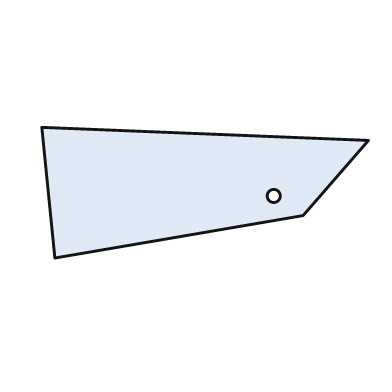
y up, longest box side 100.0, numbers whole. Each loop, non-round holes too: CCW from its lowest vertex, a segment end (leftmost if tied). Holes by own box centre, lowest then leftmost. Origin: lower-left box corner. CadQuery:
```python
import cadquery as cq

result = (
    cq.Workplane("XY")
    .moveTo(4.0, 0.0)
    .lineTo(80.0, 13.0)
    .lineTo(100.0, 36.0)
    .lineTo(0.0, 40.0)
    .close()
    .moveTo(71.0, 19.0)
    .circle(2.0)
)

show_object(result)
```